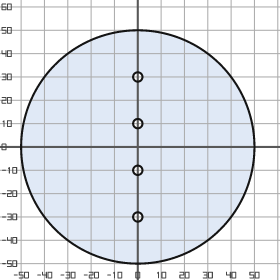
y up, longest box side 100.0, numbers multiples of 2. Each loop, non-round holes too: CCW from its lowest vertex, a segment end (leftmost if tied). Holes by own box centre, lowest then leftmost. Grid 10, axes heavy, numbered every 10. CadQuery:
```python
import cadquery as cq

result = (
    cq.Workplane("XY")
    .moveTo(0.0, 0.0)
    .circle(50.0)
    .moveTo(0.0, -30.0)
    .circle(2.0)
    .moveTo(0.0, -10.0)
    .circle(2.0)
    .moveTo(0.0, 10.0)
    .circle(2.0)
    .moveTo(0.0, 30.0)
    .circle(2.0)
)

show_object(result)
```